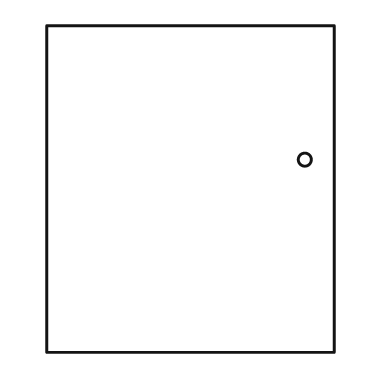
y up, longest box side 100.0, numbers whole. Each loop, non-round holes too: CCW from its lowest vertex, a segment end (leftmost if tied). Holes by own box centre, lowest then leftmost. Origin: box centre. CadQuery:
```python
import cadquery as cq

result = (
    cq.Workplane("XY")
    .moveTo(-44.0, -50.0)
    .lineTo(44.0, -50.0)
    .lineTo(44.0, 50.0)
    .lineTo(-44.0, 50.0)
    .close()
    .moveTo(35.0, 9.0)
    .circle(2.0)
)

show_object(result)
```